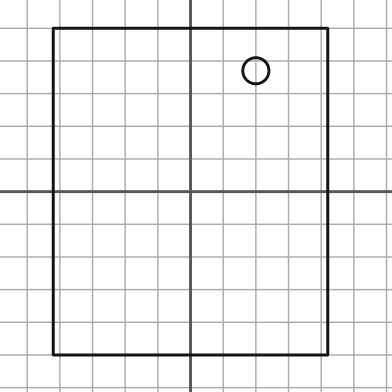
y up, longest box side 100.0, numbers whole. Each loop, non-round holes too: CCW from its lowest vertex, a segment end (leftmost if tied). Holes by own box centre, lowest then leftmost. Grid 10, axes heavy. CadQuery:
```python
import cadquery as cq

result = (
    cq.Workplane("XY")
    .moveTo(-42.0, -50.0)
    .lineTo(42.0, -50.0)
    .lineTo(42.0, 50.0)
    .lineTo(-42.0, 50.0)
    .close()
    .moveTo(20.0, 37.0)
    .circle(4.0)
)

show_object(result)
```